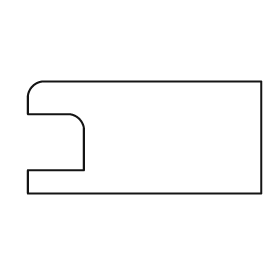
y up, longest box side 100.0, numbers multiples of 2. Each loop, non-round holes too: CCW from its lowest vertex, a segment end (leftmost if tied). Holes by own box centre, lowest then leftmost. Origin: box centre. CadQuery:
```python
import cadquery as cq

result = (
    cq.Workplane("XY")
    .moveTo(-50.0, -24.0)
    .lineTo(50.0, -24.0)
    .lineTo(50.0, 24.0)
    .lineTo(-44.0, 24.0)
    .threePointArc((-48.0, 22.0), (-50.0, 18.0))
    .lineTo(-50.0, 10.0)
    .lineTo(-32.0, 10.0)
    .threePointArc((-28.0, 8.0), (-26.0, 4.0))
    .lineTo(-26.0, -14.0)
    .lineTo(-50.0, -14.0)
    .close()
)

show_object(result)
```